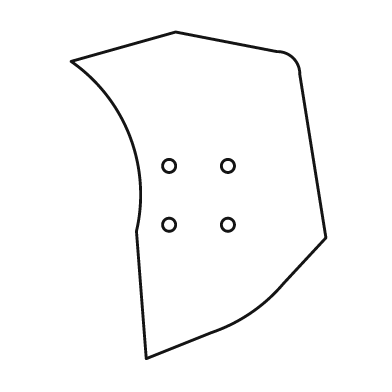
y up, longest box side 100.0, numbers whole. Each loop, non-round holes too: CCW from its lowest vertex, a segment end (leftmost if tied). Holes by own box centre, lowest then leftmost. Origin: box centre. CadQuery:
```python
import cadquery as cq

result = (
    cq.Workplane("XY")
    .moveTo(-16.0, -50.0)
    .lineTo(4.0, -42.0)
    .threePointArc((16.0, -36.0), (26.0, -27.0))
    .lineTo(39.0, -13.0)
    .lineTo(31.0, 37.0)
    .threePointArc((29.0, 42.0), (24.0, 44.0))
    .lineTo(-7.0, 50.0)
    .lineTo(-39.0, 41.0)
    .threePointArc((-21.0, 18.0), (-19.0, -11.0))
    .close()
    .moveTo(-9.0, -9.0)
    .circle(2.0)
    .moveTo(9.0, -9.0)
    .circle(2.0)
    .moveTo(-9.0, 9.0)
    .circle(2.0)
    .moveTo(9.0, 9.0)
    .circle(2.0)
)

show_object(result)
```